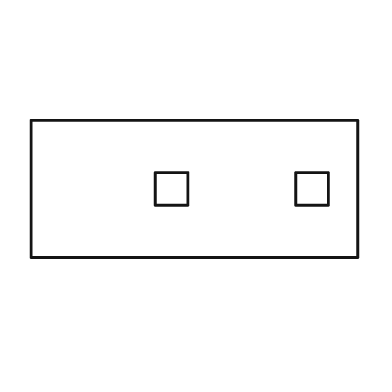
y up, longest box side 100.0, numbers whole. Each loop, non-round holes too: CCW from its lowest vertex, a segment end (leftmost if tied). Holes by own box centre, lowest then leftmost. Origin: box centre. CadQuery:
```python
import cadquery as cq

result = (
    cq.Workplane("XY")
    .moveTo(-50.0, -21.0)
    .lineTo(50.0, -21.0)
    .lineTo(50.0, 21.0)
    .lineTo(-50.0, 21.0)
    .close()
    .moveTo(-12.0, -5.0)
    .lineTo(-2.0, -5.0)
    .lineTo(-2.0, 5.0)
    .lineTo(-12.0, 5.0)
    .close()
    .moveTo(31.0, -5.0)
    .lineTo(41.0, -5.0)
    .lineTo(41.0, 5.0)
    .lineTo(31.0, 5.0)
    .close()
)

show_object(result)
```